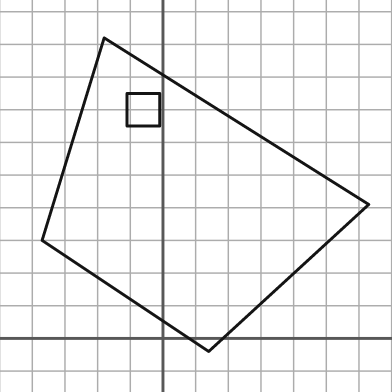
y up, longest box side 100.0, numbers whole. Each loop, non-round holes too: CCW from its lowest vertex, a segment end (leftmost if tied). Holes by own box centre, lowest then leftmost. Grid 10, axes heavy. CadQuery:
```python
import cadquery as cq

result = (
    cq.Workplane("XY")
    .moveTo(14.0, -4.0)
    .lineTo(63.0, 41.0)
    .lineTo(-18.0, 92.0)
    .lineTo(-37.0, 30.0)
    .close()
    .moveTo(-11.0, 65.0)
    .lineTo(-1.0, 65.0)
    .lineTo(-1.0, 75.0)
    .lineTo(-11.0, 75.0)
    .close()
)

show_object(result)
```